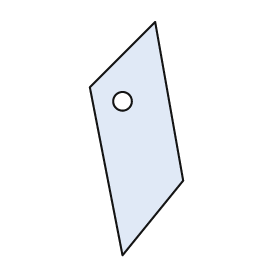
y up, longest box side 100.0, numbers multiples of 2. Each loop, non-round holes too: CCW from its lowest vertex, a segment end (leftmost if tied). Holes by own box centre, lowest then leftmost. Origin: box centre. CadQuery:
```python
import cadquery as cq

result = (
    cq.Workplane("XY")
    .moveTo(-6.0, -50.0)
    .lineTo(20.0, -18.0)
    .lineTo(8.0, 50.0)
    .lineTo(-20.0, 22.0)
    .close()
    .moveTo(-6.0, 16.0)
    .circle(4.0)
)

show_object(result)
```